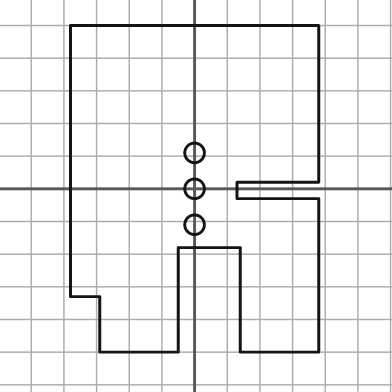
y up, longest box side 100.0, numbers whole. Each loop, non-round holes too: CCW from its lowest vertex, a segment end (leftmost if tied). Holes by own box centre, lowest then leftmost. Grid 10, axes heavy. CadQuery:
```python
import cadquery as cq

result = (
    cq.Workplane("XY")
    .moveTo(-29.0, -50.0)
    .lineTo(-5.0, -50.0)
    .lineTo(-5.0, -18.0)
    .lineTo(14.0, -18.0)
    .lineTo(14.0, -50.0)
    .lineTo(38.0, -50.0)
    .lineTo(38.0, -3.0)
    .lineTo(13.0, -3.0)
    .lineTo(13.0, 2.0)
    .lineTo(38.0, 2.0)
    .lineTo(38.0, 50.0)
    .lineTo(-38.0, 50.0)
    .lineTo(-38.0, -33.0)
    .lineTo(-29.0, -33.0)
    .close()
    .moveTo(0.0, -11.0)
    .circle(3.0)
    .moveTo(0.0, 0.0)
    .circle(3.0)
    .moveTo(0.0, 11.0)
    .circle(3.0)
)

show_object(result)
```